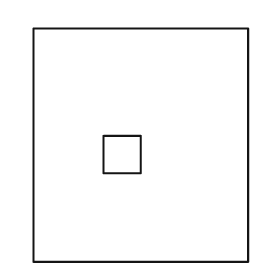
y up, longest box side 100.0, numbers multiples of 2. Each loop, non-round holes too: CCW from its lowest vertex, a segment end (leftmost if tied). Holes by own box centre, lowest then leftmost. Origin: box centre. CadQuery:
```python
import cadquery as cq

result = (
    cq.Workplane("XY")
    .moveTo(-46.0, -50.0)
    .lineTo(46.0, -50.0)
    .lineTo(46.0, 50.0)
    .lineTo(-46.0, 50.0)
    .close()
    .moveTo(-16.0, -12.0)
    .lineTo(0.0, -12.0)
    .lineTo(0.0, 4.0)
    .lineTo(-16.0, 4.0)
    .close()
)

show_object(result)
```